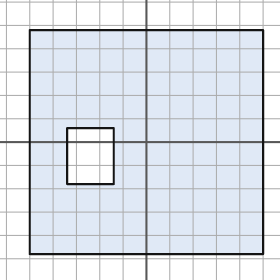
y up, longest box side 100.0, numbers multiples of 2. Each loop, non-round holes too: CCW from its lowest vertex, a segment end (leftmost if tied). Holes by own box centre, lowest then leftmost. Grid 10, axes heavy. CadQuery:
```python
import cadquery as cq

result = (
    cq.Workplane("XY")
    .moveTo(-50.0, -48.0)
    .lineTo(50.0, -48.0)
    .lineTo(50.0, 48.0)
    .lineTo(-50.0, 48.0)
    .close()
    .moveTo(-34.0, -18.0)
    .lineTo(-14.0, -18.0)
    .lineTo(-14.0, 6.0)
    .lineTo(-34.0, 6.0)
    .close()
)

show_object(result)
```